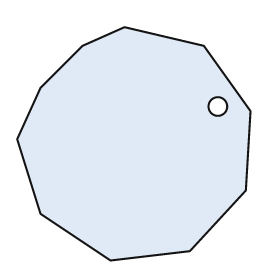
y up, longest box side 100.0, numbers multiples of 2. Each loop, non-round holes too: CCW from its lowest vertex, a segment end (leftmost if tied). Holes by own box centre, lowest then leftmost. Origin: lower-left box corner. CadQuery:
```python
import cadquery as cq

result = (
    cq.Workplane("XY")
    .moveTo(40.0, 0.0)
    .lineTo(74.0, 4.0)
    .lineTo(98.0, 30.0)
    .lineTo(100.0, 64.0)
    .lineTo(80.0, 92.0)
    .lineTo(46.0, 100.0)
    .lineTo(28.0, 92.0)
    .lineTo(10.0, 74.0)
    .lineTo(0.0, 52.0)
    .lineTo(10.0, 20.0)
    .close()
    .moveTo(86.0, 66.0)
    .circle(4.0)
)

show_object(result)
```